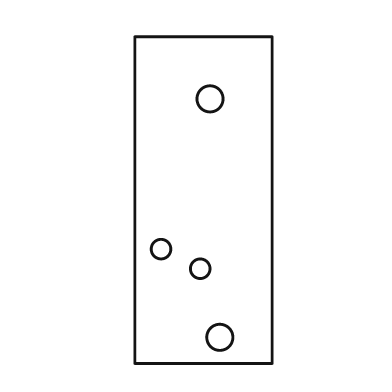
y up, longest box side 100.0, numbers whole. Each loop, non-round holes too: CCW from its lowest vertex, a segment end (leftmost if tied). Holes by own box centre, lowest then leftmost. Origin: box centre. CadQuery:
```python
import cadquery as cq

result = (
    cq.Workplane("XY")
    .moveTo(-21.0, -50.0)
    .lineTo(21.0, -50.0)
    .lineTo(21.0, 50.0)
    .lineTo(-21.0, 50.0)
    .close()
    .moveTo(5.0, -42.0)
    .circle(4.0)
    .moveTo(-1.0, -21.0)
    .circle(3.0)
    .moveTo(-13.0, -15.0)
    .circle(3.0)
    .moveTo(2.0, 31.0)
    .circle(4.0)
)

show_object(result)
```